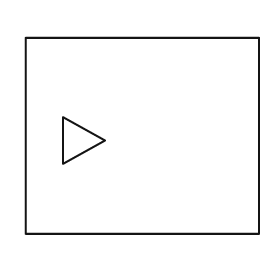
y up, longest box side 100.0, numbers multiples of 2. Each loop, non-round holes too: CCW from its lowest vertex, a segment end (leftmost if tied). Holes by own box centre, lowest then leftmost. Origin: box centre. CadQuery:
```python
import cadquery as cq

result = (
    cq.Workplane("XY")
    .moveTo(-50.0, -42.0)
    .lineTo(50.0, -42.0)
    .lineTo(50.0, 42.0)
    .lineTo(-50.0, 42.0)
    .close()
    .moveTo(-34.0, -12.0)
    .lineTo(-16.0, -2.0)
    .lineTo(-34.0, 8.0)
    .close()
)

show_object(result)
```